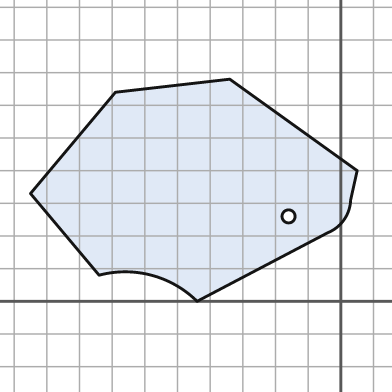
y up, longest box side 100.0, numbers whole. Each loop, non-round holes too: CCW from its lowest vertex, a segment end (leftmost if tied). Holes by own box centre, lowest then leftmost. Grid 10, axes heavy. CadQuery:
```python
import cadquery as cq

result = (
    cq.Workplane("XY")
    .moveTo(-44.0, 0.0)
    .lineTo(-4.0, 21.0)
    .threePointArc((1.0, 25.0), (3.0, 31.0))
    .lineTo(5.0, 40.0)
    .lineTo(-34.0, 68.0)
    .lineTo(-69.0, 64.0)
    .lineTo(-95.0, 33.0)
    .lineTo(-74.0, 8.0)
    .threePointArc((-58.0, 8.0), (-44.0, 0.0))
    .close()
    .moveTo(-16.0, 26.0)
    .circle(2.0)
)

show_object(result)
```